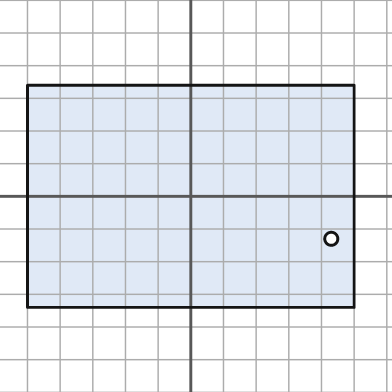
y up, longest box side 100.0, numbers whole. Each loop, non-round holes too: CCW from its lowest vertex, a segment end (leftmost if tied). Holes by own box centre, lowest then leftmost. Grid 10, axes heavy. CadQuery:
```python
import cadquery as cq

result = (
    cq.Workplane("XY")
    .moveTo(-50.0, -34.0)
    .lineTo(50.0, -34.0)
    .lineTo(50.0, 34.0)
    .lineTo(-50.0, 34.0)
    .close()
    .moveTo(43.0, -13.0)
    .circle(2.0)
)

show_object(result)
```